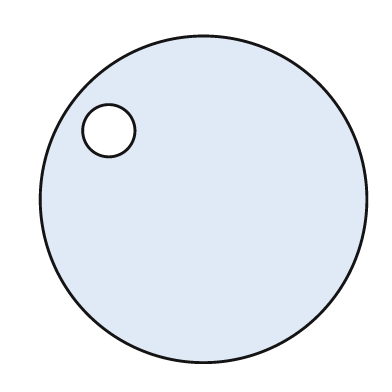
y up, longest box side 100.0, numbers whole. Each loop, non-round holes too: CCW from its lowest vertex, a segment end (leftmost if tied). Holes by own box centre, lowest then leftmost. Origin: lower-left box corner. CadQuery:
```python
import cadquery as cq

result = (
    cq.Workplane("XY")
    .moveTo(50.0, 50.0)
    .circle(50.0)
    .moveTo(21.0, 71.0)
    .circle(8.0)
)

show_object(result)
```